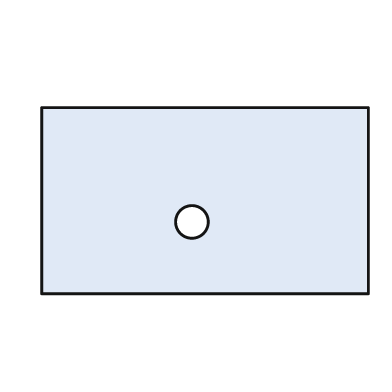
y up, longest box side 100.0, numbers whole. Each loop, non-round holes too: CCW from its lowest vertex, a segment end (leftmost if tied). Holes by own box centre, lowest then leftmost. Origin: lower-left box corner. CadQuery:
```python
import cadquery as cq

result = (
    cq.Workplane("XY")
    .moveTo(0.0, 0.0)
    .lineTo(100.0, 0.0)
    .lineTo(100.0, 57.0)
    .lineTo(0.0, 57.0)
    .close()
    .moveTo(46.0, 22.0)
    .circle(5.0)
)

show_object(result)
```